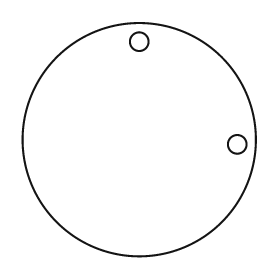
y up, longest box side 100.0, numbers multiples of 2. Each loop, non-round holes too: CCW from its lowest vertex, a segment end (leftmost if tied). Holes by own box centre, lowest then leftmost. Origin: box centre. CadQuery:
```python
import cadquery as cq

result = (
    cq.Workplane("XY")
    .moveTo(0.0, 0.0)
    .circle(50.0)
    .moveTo(42.0, -2.0)
    .circle(4.0)
    .moveTo(0.0, 42.0)
    .circle(4.0)
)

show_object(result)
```